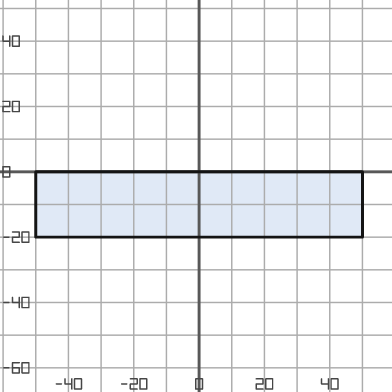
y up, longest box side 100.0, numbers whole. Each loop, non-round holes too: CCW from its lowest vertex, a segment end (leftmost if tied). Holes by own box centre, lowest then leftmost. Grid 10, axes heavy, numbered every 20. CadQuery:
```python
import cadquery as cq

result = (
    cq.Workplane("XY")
    .moveTo(-50.0, -20.0)
    .lineTo(50.0, -20.0)
    .lineTo(50.0, 0.0)
    .lineTo(-50.0, 0.0)
    .close()
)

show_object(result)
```